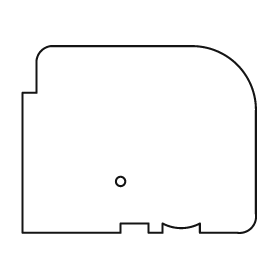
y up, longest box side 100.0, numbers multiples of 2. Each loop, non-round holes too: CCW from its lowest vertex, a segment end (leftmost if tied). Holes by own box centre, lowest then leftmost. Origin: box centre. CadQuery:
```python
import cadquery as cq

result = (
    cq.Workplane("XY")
    .moveTo(-50.0, -40.0)
    .lineTo(-8.0, -40.0)
    .lineTo(-8.0, -36.0)
    .lineTo(4.0, -36.0)
    .lineTo(4.0, -40.0)
    .lineTo(10.0, -40.0)
    .lineTo(10.0, -36.0)
    .threePointArc((18.0, -38.0), (26.0, -36.0))
    .lineTo(26.0, -40.0)
    .lineTo(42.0, -40.0)
    .threePointArc((48.0, -38.0), (50.0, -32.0))
    .lineTo(50.0, 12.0)
    .threePointArc((42.0, 32.0), (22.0, 40.0))
    .lineTo(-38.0, 40.0)
    .threePointArc((-42.0, 38.0), (-44.0, 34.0))
    .lineTo(-44.0, 20.0)
    .lineTo(-50.0, 20.0)
    .close()
    .moveTo(-8.0, -18.0)
    .circle(2.0)
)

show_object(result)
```